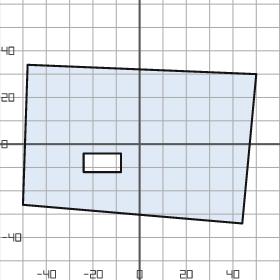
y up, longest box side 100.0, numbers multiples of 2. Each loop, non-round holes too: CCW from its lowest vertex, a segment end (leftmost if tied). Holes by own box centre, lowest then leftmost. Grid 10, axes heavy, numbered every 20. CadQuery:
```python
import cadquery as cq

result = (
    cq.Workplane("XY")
    .moveTo(44.0, -34.0)
    .lineTo(50.0, 30.0)
    .lineTo(-48.0, 34.0)
    .lineTo(-50.0, -26.0)
    .close()
    .moveTo(-24.0, -12.0)
    .lineTo(-8.0, -12.0)
    .lineTo(-8.0, -4.0)
    .lineTo(-24.0, -4.0)
    .close()
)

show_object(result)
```